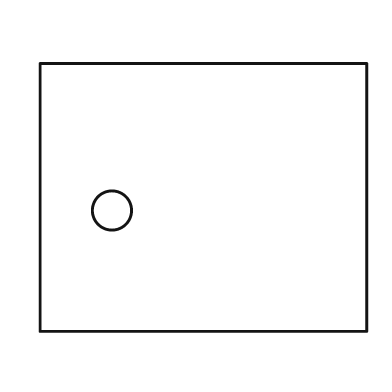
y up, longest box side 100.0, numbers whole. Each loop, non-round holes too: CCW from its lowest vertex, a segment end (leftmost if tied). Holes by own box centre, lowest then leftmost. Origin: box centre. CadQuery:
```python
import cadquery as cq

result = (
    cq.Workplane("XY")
    .moveTo(-50.0, -41.0)
    .lineTo(50.0, -41.0)
    .lineTo(50.0, 41.0)
    .lineTo(-50.0, 41.0)
    .close()
    .moveTo(-28.0, -4.0)
    .circle(6.0)
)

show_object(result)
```